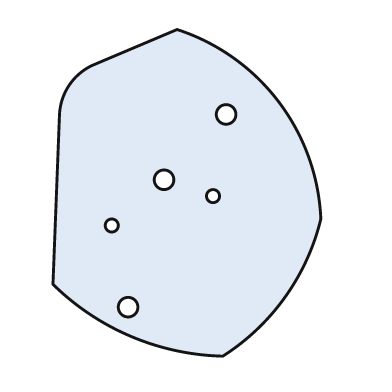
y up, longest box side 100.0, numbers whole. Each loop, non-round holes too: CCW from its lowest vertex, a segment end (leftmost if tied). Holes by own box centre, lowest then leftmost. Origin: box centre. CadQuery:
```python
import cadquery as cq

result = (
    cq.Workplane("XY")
    .moveTo(11.0, -50.0)
    .threePointArc((30.0, -32.0), (41.0, -8.0))
    .threePointArc((28.0, 28.0), (-3.0, 50.0))
    .lineTo(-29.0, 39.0)
    .threePointArc((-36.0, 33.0), (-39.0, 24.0))
    .lineTo(-41.0, -28.0)
    .threePointArc((-17.0, -44.0), (11.0, -50.0))
    .close()
    .moveTo(-18.0, -35.0)
    .circle(3.0)
    .moveTo(-23.0, -10.0)
    .circle(2.0)
    .moveTo(8.0, -1.0)
    .circle(2.0)
    .moveTo(-7.0, 4.0)
    .circle(3.0)
    .moveTo(12.0, 24.0)
    .circle(3.0)
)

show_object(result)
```